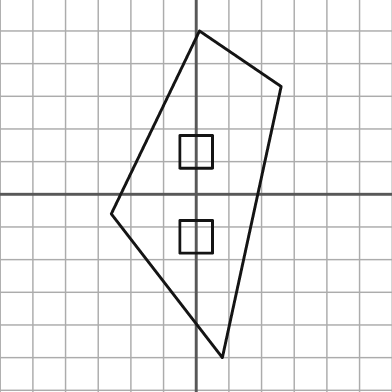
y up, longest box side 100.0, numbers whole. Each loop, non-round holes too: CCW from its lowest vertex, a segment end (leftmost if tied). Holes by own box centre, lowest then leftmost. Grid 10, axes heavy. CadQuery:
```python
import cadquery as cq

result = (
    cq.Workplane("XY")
    .moveTo(8.0, -50.0)
    .lineTo(26.0, 33.0)
    .lineTo(1.0, 50.0)
    .lineTo(-26.0, -6.0)
    .close()
    .moveTo(-5.0, -18.0)
    .lineTo(5.0, -18.0)
    .lineTo(5.0, -8.0)
    .lineTo(-5.0, -8.0)
    .close()
    .moveTo(-5.0, 8.0)
    .lineTo(5.0, 8.0)
    .lineTo(5.0, 18.0)
    .lineTo(-5.0, 18.0)
    .close()
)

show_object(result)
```